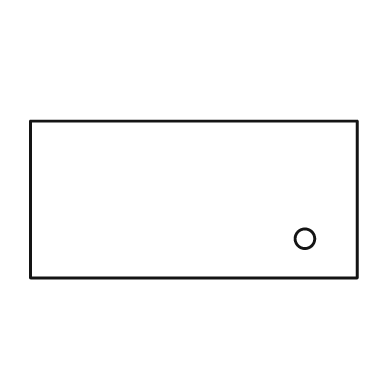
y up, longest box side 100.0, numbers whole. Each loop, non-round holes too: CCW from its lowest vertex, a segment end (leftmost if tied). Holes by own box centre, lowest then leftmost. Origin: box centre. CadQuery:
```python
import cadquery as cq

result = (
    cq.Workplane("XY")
    .moveTo(-50.0, -24.0)
    .lineTo(50.0, -24.0)
    .lineTo(50.0, 24.0)
    .lineTo(-50.0, 24.0)
    .close()
    .moveTo(34.0, -12.0)
    .circle(3.0)
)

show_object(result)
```